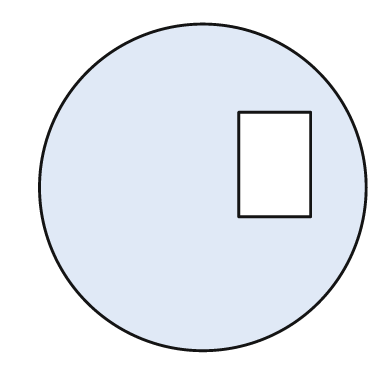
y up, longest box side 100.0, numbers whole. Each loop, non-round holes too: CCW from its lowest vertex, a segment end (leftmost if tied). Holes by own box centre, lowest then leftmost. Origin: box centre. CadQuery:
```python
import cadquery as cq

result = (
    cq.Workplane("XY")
    .moveTo(0.0, 0.0)
    .circle(50.0)
    .moveTo(11.0, -9.0)
    .lineTo(33.0, -9.0)
    .lineTo(33.0, 23.0)
    .lineTo(11.0, 23.0)
    .close()
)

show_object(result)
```